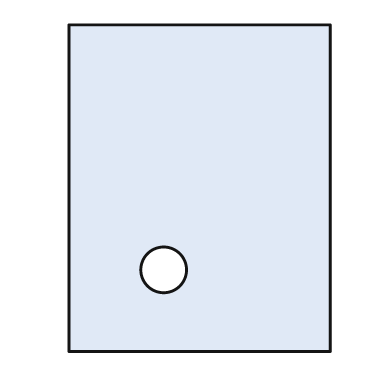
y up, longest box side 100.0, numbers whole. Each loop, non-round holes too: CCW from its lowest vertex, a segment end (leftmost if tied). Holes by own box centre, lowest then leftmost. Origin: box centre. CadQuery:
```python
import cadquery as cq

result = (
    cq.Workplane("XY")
    .moveTo(-40.0, -50.0)
    .lineTo(40.0, -50.0)
    .lineTo(40.0, 50.0)
    .lineTo(-40.0, 50.0)
    .close()
    .moveTo(-11.0, -25.0)
    .circle(7.0)
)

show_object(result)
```